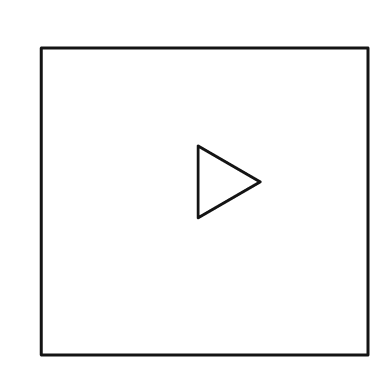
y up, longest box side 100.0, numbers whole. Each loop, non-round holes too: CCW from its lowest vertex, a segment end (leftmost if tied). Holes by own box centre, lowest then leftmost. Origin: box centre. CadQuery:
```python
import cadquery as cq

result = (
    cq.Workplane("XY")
    .moveTo(-50.0, -47.0)
    .lineTo(50.0, -47.0)
    .lineTo(50.0, 47.0)
    .lineTo(-50.0, 47.0)
    .close()
    .moveTo(-2.0, -5.0)
    .lineTo(17.0, 6.0)
    .lineTo(-2.0, 17.0)
    .close()
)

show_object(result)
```